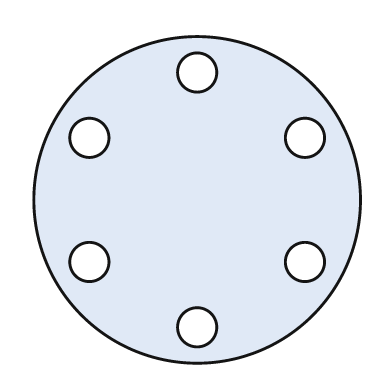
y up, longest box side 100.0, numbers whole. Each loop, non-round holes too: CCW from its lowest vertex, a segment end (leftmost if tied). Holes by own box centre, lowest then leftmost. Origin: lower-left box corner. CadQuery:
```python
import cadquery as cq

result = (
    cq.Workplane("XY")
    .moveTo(50.0, 50.0)
    .circle(50.0)
    .moveTo(50.0, 11.0)
    .circle(6.0)
    .moveTo(17.0, 31.0)
    .circle(6.0)
    .moveTo(83.0, 31.0)
    .circle(6.0)
    .moveTo(17.0, 69.0)
    .circle(6.0)
    .moveTo(83.0, 69.0)
    .circle(6.0)
    .moveTo(50.0, 89.0)
    .circle(6.0)
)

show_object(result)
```